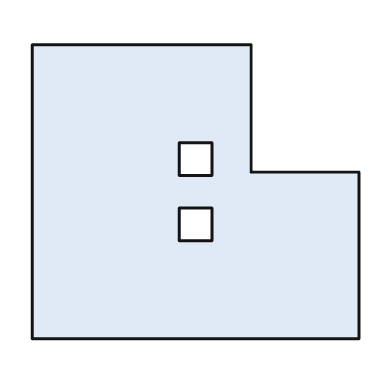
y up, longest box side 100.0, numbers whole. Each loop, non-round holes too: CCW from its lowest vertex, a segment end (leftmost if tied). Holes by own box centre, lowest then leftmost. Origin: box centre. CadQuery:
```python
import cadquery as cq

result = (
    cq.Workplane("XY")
    .moveTo(-50.0, -45.0)
    .lineTo(50.0, -45.0)
    .lineTo(50.0, 6.0)
    .lineTo(17.0, 6.0)
    .lineTo(17.0, 45.0)
    .lineTo(-50.0, 45.0)
    .close()
    .moveTo(-5.0, -15.0)
    .lineTo(5.0, -15.0)
    .lineTo(5.0, -5.0)
    .lineTo(-5.0, -5.0)
    .close()
    .moveTo(-5.0, 5.0)
    .lineTo(5.0, 5.0)
    .lineTo(5.0, 15.0)
    .lineTo(-5.0, 15.0)
    .close()
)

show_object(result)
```